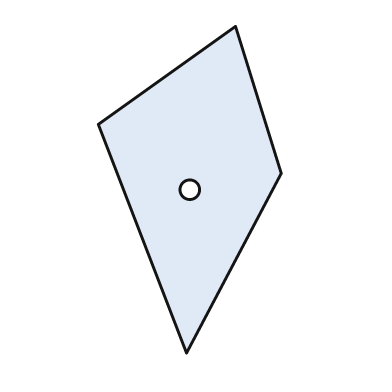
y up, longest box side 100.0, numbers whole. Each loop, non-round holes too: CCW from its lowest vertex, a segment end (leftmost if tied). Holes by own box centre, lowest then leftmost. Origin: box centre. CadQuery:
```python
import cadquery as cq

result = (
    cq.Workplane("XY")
    .moveTo(-1.0, -50.0)
    .lineTo(28.0, 5.0)
    .lineTo(14.0, 50.0)
    .lineTo(-28.0, 20.0)
    .close()
    .moveTo(0.0, 0.0)
    .circle(3.0)
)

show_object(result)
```